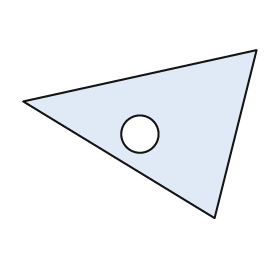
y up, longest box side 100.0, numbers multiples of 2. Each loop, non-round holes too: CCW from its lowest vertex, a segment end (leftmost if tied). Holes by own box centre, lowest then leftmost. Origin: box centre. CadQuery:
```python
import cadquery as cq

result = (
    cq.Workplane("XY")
    .moveTo(32.0, -36.0)
    .lineTo(50.0, 36.0)
    .lineTo(-50.0, 14.0)
    .close()
    .moveTo(0.0, 0.0)
    .circle(8.0)
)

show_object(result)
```